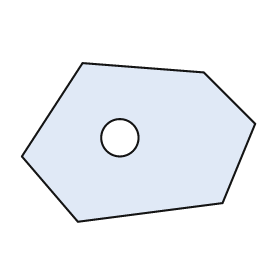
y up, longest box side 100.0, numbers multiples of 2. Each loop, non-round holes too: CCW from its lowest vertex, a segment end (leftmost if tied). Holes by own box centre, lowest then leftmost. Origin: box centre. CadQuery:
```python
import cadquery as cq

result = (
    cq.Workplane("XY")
    .moveTo(-26.0, -34.0)
    .lineTo(36.0, -26.0)
    .lineTo(50.0, 8.0)
    .lineTo(28.0, 30.0)
    .lineTo(-24.0, 34.0)
    .lineTo(-50.0, -6.0)
    .close()
    .moveTo(-8.0, 2.0)
    .circle(8.0)
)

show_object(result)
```